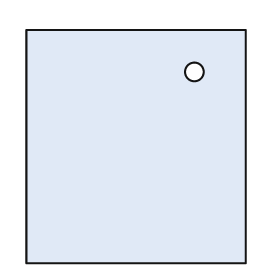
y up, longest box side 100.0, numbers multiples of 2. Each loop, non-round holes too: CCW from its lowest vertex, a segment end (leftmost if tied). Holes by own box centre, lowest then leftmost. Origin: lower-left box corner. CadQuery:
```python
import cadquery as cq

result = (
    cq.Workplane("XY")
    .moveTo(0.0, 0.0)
    .lineTo(94.0, 0.0)
    .lineTo(94.0, 100.0)
    .lineTo(0.0, 100.0)
    .close()
    .moveTo(72.0, 82.0)
    .circle(4.0)
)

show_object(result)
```